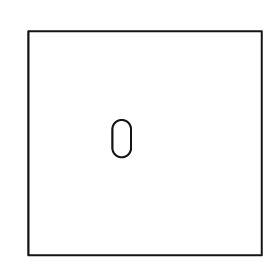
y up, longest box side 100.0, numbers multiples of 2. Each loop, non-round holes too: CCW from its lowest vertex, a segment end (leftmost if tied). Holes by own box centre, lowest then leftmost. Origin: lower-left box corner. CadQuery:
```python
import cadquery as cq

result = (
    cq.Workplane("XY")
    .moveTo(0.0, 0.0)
    .lineTo(100.0, 0.0)
    .lineTo(100.0, 96.0)
    .lineTo(0.0, 96.0)
    .close()
    .moveTo(36.0, 46.0)
    .threePointArc((40.0, 42.0), (44.0, 46.0))
    .lineTo(44.0, 54.0)
    .threePointArc((40.0, 58.0), (36.0, 54.0))
    .close()
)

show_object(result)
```